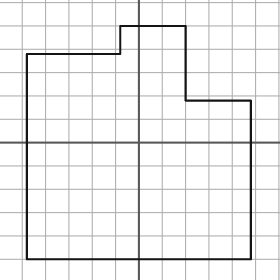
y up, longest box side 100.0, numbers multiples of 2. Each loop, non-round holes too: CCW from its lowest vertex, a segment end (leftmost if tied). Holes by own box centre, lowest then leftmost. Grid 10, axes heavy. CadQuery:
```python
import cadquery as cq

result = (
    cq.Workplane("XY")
    .moveTo(-48.0, -50.0)
    .lineTo(48.0, -50.0)
    .lineTo(48.0, 18.0)
    .lineTo(20.0, 18.0)
    .lineTo(20.0, 50.0)
    .lineTo(-8.0, 50.0)
    .lineTo(-8.0, 38.0)
    .lineTo(-48.0, 38.0)
    .close()
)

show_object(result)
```